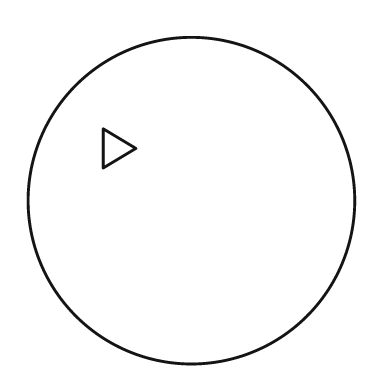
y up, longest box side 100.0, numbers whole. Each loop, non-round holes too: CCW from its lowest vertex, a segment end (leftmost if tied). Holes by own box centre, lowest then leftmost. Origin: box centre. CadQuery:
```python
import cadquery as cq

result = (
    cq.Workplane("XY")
    .moveTo(0.0, 0.0)
    .circle(50.0)
    .moveTo(-27.0, 10.0)
    .lineTo(-17.0, 16.0)
    .lineTo(-27.0, 22.0)
    .close()
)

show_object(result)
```